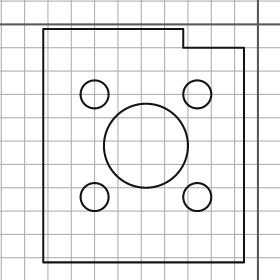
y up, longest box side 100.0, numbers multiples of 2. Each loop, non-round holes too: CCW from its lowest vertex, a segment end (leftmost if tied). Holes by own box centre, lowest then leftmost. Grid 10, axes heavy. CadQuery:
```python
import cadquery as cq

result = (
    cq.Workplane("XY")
    .moveTo(-92.0, -102.0)
    .lineTo(-6.0, -102.0)
    .lineTo(-6.0, -10.0)
    .lineTo(-32.0, -10.0)
    .lineTo(-32.0, -2.0)
    .lineTo(-92.0, -2.0)
    .close()
    .moveTo(-70.0, -74.0)
    .circle(6.0)
    .moveTo(-26.0, -74.0)
    .circle(6.0)
    .moveTo(-48.0, -52.0)
    .circle(18.0)
    .moveTo(-70.0, -30.0)
    .circle(6.0)
    .moveTo(-26.0, -30.0)
    .circle(6.0)
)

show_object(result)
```